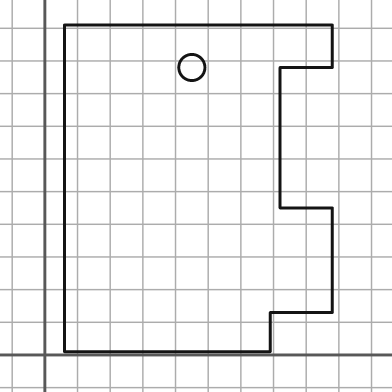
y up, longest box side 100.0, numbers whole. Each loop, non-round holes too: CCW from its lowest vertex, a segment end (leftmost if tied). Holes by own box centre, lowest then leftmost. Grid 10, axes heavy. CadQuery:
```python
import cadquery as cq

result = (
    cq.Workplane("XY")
    .moveTo(6.0, 1.0)
    .lineTo(69.0, 1.0)
    .lineTo(69.0, 13.0)
    .lineTo(88.0, 13.0)
    .lineTo(88.0, 45.0)
    .lineTo(72.0, 45.0)
    .lineTo(72.0, 88.0)
    .lineTo(88.0, 88.0)
    .lineTo(88.0, 101.0)
    .lineTo(6.0, 101.0)
    .close()
    .moveTo(45.0, 88.0)
    .circle(4.0)
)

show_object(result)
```